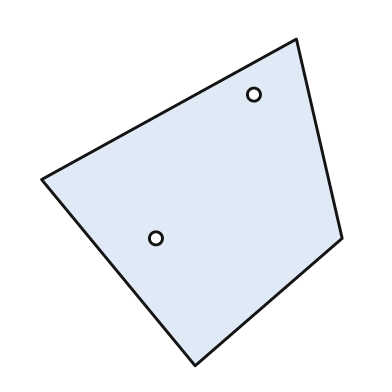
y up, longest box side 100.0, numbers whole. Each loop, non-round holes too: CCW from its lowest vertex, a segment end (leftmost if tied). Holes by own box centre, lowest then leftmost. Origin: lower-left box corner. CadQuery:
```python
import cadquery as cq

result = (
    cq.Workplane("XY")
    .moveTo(47.0, 0.0)
    .lineTo(92.0, 39.0)
    .lineTo(78.0, 100.0)
    .lineTo(0.0, 57.0)
    .close()
    .moveTo(35.0, 39.0)
    .circle(2.0)
    .moveTo(65.0, 83.0)
    .circle(2.0)
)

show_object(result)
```